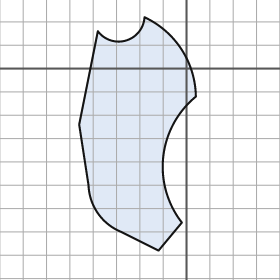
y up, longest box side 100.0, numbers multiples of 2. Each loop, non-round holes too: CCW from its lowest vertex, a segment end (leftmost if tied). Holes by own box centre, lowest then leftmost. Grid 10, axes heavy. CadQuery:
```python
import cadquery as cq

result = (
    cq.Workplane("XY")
    .moveTo(-12.0, -78.0)
    .lineTo(-2.0, -66.0)
    .threePointArc((-10.0, -38.0), (4.0, -12.0))
    .threePointArc((-2.0, 8.0), (-18.0, 22.0))
    .threePointArc((-26.0, 12.0), (-38.0, 16.0))
    .lineTo(-46.0, -24.0)
    .lineTo(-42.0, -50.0)
    .threePointArc((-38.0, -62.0), (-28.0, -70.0))
    .close()
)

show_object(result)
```